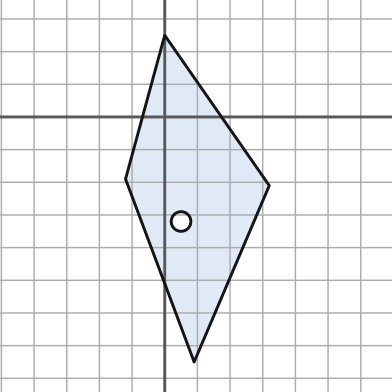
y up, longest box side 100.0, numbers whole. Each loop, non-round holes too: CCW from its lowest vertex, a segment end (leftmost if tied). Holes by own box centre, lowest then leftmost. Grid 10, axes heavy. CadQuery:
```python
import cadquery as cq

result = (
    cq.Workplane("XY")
    .moveTo(9.0, -75.0)
    .lineTo(32.0, -21.0)
    .lineTo(0.0, 25.0)
    .lineTo(-12.0, -19.0)
    .close()
    .moveTo(5.0, -32.0)
    .circle(3.0)
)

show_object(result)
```